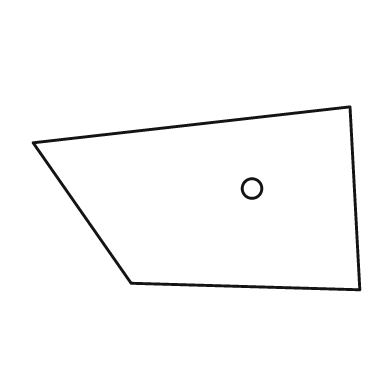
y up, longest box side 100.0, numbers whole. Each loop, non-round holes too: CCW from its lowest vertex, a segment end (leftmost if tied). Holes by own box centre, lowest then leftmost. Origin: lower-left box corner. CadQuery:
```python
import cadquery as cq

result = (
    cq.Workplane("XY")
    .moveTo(100.0, 0.0)
    .lineTo(97.0, 56.0)
    .lineTo(0.0, 45.0)
    .lineTo(30.0, 2.0)
    .close()
    .moveTo(67.0, 31.0)
    .circle(3.0)
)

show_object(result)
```